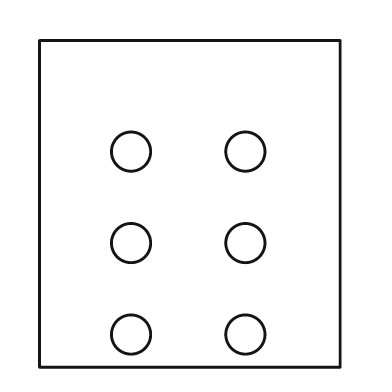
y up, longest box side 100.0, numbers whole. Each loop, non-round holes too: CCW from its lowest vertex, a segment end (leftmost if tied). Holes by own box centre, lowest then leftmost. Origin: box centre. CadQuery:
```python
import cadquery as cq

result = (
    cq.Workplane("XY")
    .moveTo(-46.0, -50.0)
    .lineTo(46.0, -50.0)
    .lineTo(46.0, 50.0)
    .lineTo(-46.0, 50.0)
    .close()
    .moveTo(-18.0, -40.0)
    .circle(6.0)
    .moveTo(17.0, -40.0)
    .circle(6.0)
    .moveTo(-18.0, -12.0)
    .circle(6.0)
    .moveTo(17.0, -12.0)
    .circle(6.0)
    .moveTo(-18.0, 16.0)
    .circle(6.0)
    .moveTo(17.0, 16.0)
    .circle(6.0)
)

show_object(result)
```